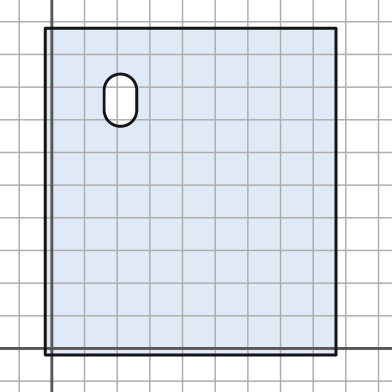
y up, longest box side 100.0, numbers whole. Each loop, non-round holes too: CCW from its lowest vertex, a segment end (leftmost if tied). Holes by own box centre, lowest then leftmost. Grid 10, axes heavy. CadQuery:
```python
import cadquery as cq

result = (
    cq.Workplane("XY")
    .moveTo(-2.0, -2.0)
    .lineTo(87.0, -2.0)
    .lineTo(87.0, 98.0)
    .lineTo(-2.0, 98.0)
    .close()
    .moveTo(16.0, 73.0)
    .threePointArc((21.0, 68.0), (26.0, 73.0))
    .lineTo(26.0, 79.0)
    .threePointArc((21.0, 84.0), (16.0, 79.0))
    .close()
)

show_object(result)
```